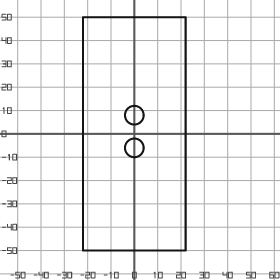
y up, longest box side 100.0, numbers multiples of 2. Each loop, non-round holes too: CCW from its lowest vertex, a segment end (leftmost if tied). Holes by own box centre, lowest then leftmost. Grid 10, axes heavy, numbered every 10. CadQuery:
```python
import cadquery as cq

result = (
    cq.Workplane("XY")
    .moveTo(-22.0, -50.0)
    .lineTo(22.0, -50.0)
    .lineTo(22.0, 50.0)
    .lineTo(-22.0, 50.0)
    .close()
    .moveTo(0.0, -6.0)
    .circle(4.0)
    .moveTo(0.0, 8.0)
    .circle(4.0)
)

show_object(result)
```